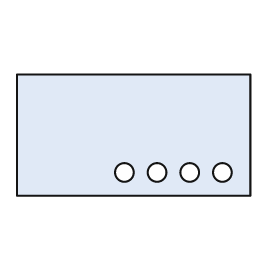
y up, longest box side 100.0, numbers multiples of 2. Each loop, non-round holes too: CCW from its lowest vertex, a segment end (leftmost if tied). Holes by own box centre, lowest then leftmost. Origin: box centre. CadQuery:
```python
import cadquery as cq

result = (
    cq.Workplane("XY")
    .moveTo(-50.0, -26.0)
    .lineTo(50.0, -26.0)
    .lineTo(50.0, 26.0)
    .lineTo(-50.0, 26.0)
    .close()
    .moveTo(-4.0, -16.0)
    .circle(4.0)
    .moveTo(10.0, -16.0)
    .circle(4.0)
    .moveTo(24.0, -16.0)
    .circle(4.0)
    .moveTo(38.0, -16.0)
    .circle(4.0)
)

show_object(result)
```